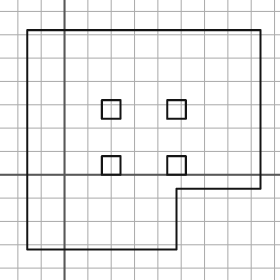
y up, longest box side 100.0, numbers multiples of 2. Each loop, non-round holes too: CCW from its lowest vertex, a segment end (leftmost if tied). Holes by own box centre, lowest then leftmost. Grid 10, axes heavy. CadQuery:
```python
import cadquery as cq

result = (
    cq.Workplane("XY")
    .moveTo(-16.0, -32.0)
    .lineTo(48.0, -32.0)
    .lineTo(48.0, -6.0)
    .lineTo(84.0, -6.0)
    .lineTo(84.0, 62.0)
    .lineTo(-16.0, 62.0)
    .close()
    .moveTo(16.0, 0.0)
    .lineTo(24.0, 0.0)
    .lineTo(24.0, 8.0)
    .lineTo(16.0, 8.0)
    .close()
    .moveTo(44.0, 0.0)
    .lineTo(52.0, 0.0)
    .lineTo(52.0, 8.0)
    .lineTo(44.0, 8.0)
    .close()
    .moveTo(16.0, 24.0)
    .lineTo(24.0, 24.0)
    .lineTo(24.0, 32.0)
    .lineTo(16.0, 32.0)
    .close()
    .moveTo(44.0, 24.0)
    .lineTo(52.0, 24.0)
    .lineTo(52.0, 32.0)
    .lineTo(44.0, 32.0)
    .close()
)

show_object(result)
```